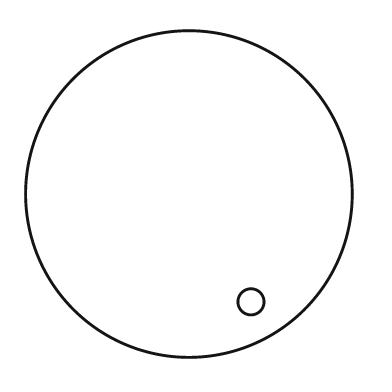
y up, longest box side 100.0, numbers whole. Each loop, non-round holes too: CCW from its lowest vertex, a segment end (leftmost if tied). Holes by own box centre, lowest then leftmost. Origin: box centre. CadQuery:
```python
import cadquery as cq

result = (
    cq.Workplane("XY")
    .moveTo(0.0, 0.0)
    .circle(50.0)
    .moveTo(19.0, -33.0)
    .circle(4.0)
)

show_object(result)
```